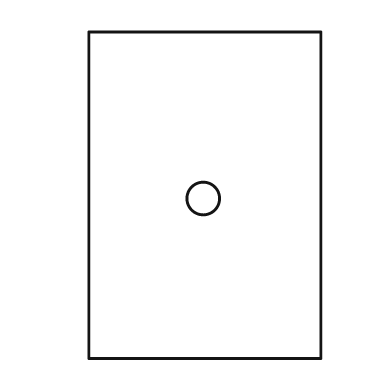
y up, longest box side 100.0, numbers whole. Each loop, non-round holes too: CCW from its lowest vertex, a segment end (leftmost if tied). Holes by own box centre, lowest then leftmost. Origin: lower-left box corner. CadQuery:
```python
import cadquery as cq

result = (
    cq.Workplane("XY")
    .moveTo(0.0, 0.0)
    .lineTo(71.0, 0.0)
    .lineTo(71.0, 100.0)
    .lineTo(0.0, 100.0)
    .close()
    .moveTo(35.0, 49.0)
    .circle(5.0)
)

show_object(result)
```